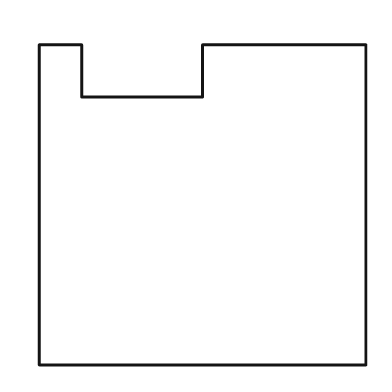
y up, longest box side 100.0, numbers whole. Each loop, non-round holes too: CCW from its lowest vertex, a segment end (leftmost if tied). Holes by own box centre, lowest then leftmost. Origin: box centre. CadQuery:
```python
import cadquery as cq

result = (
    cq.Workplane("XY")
    .moveTo(-50.0, -49.0)
    .lineTo(50.0, -49.0)
    .lineTo(50.0, 49.0)
    .lineTo(0.0, 49.0)
    .lineTo(0.0, 33.0)
    .lineTo(-37.0, 33.0)
    .lineTo(-37.0, 49.0)
    .lineTo(-50.0, 49.0)
    .close()
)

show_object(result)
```